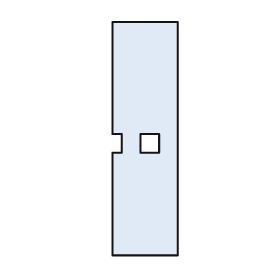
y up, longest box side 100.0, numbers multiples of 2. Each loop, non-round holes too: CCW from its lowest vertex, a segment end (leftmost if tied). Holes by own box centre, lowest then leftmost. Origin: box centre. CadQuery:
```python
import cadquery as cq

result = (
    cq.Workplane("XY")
    .moveTo(-14.0, -50.0)
    .lineTo(14.0, -50.0)
    .lineTo(14.0, 50.0)
    .lineTo(-14.0, 50.0)
    .lineTo(-14.0, 2.0)
    .lineTo(-10.0, 2.0)
    .lineTo(-10.0, -6.0)
    .lineTo(-14.0, -6.0)
    .close()
    .moveTo(-2.0, -6.0)
    .lineTo(6.0, -6.0)
    .lineTo(6.0, 2.0)
    .lineTo(-2.0, 2.0)
    .close()
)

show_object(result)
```